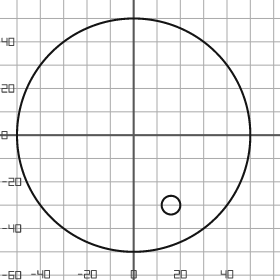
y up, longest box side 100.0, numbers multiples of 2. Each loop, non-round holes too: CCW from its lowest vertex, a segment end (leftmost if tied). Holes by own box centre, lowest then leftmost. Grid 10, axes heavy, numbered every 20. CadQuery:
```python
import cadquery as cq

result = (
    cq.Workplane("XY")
    .moveTo(0.0, 0.0)
    .circle(50.0)
    .moveTo(16.0, -30.0)
    .circle(4.0)
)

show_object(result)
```